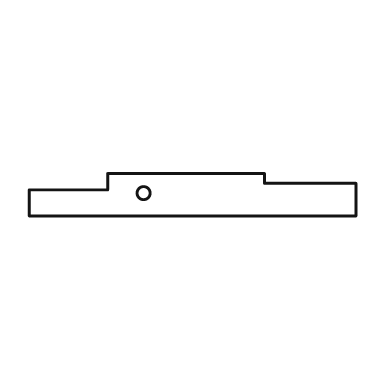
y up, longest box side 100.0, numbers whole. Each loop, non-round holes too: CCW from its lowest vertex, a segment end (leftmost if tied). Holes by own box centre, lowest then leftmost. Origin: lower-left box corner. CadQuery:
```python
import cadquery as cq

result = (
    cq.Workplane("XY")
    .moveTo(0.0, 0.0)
    .lineTo(100.0, 0.0)
    .lineTo(100.0, 10.0)
    .lineTo(72.0, 10.0)
    .lineTo(72.0, 13.0)
    .lineTo(24.0, 13.0)
    .lineTo(24.0, 8.0)
    .lineTo(0.0, 8.0)
    .close()
    .moveTo(35.0, 7.0)
    .circle(2.0)
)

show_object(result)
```